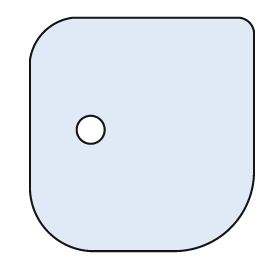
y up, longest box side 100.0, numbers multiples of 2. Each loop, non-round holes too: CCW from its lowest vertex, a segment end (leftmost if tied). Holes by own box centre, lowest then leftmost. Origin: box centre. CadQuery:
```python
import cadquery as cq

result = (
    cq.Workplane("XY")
    .moveTo(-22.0, -50.0)
    .lineTo(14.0, -50.0)
    .threePointArc((38.0, -40.0), (48.0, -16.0))
    .lineTo(48.0, 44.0)
    .threePointArc((46.0, 48.0), (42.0, 50.0))
    .lineTo(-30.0, 50.0)
    .threePointArc((-42.0, 44.0), (-48.0, 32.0))
    .lineTo(-48.0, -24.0)
    .threePointArc((-40.0, -42.0), (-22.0, -50.0))
    .close()
    .moveTo(-22.0, 2.0)
    .circle(6.0)
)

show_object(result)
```